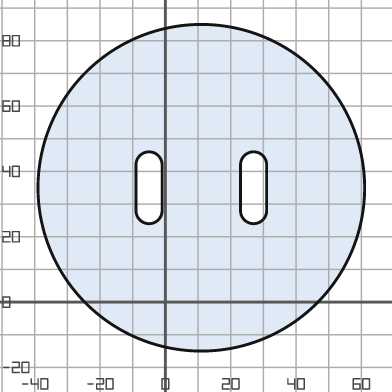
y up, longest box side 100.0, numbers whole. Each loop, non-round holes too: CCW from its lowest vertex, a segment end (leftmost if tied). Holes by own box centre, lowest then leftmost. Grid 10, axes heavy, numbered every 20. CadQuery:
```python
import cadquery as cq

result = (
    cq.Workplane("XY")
    .moveTo(11.0, 35.0)
    .circle(50.0)
    .moveTo(-9.0, 28.0)
    .threePointArc((-5.0, 24.0), (-1.0, 28.0))
    .lineTo(-1.0, 42.0)
    .threePointArc((-5.0, 46.0), (-9.0, 42.0))
    .close()
    .moveTo(23.0, 28.0)
    .threePointArc((27.0, 24.0), (31.0, 28.0))
    .lineTo(31.0, 42.0)
    .threePointArc((27.0, 46.0), (23.0, 42.0))
    .close()
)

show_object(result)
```